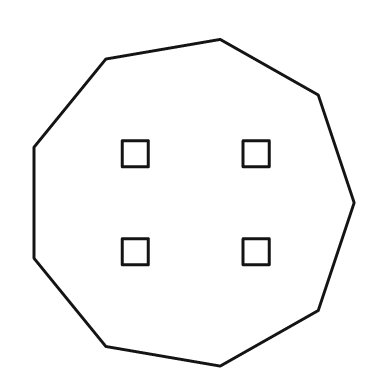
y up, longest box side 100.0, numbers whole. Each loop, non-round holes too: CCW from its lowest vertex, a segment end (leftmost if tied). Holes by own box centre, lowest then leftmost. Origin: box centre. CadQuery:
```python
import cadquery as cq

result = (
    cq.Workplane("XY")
    .moveTo(8.0, -50.0)
    .lineTo(38.0, -33.0)
    .lineTo(49.0, 0.0)
    .lineTo(38.0, 33.0)
    .lineTo(8.0, 50.0)
    .lineTo(-27.0, 44.0)
    .lineTo(-49.0, 17.0)
    .lineTo(-49.0, -17.0)
    .lineTo(-27.0, -44.0)
    .close()
    .moveTo(-22.0, -19.0)
    .lineTo(-14.0, -19.0)
    .lineTo(-14.0, -11.0)
    .lineTo(-22.0, -11.0)
    .close()
    .moveTo(15.0, -19.0)
    .lineTo(23.0, -19.0)
    .lineTo(23.0, -11.0)
    .lineTo(15.0, -11.0)
    .close()
    .moveTo(-22.0, 11.0)
    .lineTo(-14.0, 11.0)
    .lineTo(-14.0, 19.0)
    .lineTo(-22.0, 19.0)
    .close()
    .moveTo(15.0, 11.0)
    .lineTo(23.0, 11.0)
    .lineTo(23.0, 19.0)
    .lineTo(15.0, 19.0)
    .close()
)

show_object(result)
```